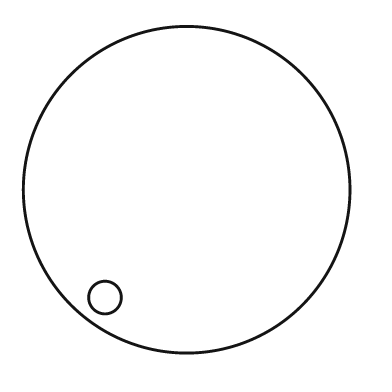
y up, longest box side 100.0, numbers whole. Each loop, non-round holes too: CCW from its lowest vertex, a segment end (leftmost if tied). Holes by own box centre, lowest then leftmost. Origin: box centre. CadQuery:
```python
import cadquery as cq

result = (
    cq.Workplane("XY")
    .moveTo(0.0, 0.0)
    .circle(50.0)
    .moveTo(-25.0, -33.0)
    .circle(5.0)
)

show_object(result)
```